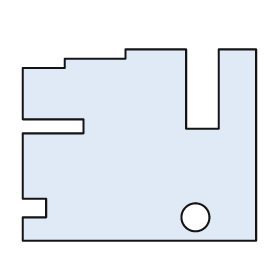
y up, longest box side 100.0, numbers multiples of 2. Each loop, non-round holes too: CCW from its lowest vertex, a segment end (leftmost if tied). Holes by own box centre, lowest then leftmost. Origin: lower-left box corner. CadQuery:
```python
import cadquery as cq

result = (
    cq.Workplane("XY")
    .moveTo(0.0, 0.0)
    .lineTo(100.0, 0.0)
    .lineTo(100.0, 82.0)
    .lineTo(84.0, 82.0)
    .lineTo(84.0, 48.0)
    .lineTo(70.0, 48.0)
    .lineTo(70.0, 82.0)
    .lineTo(44.0, 82.0)
    .lineTo(44.0, 78.0)
    .lineTo(18.0, 78.0)
    .lineTo(18.0, 74.0)
    .lineTo(0.0, 74.0)
    .lineTo(0.0, 52.0)
    .lineTo(26.0, 52.0)
    .lineTo(26.0, 46.0)
    .lineTo(0.0, 46.0)
    .lineTo(0.0, 18.0)
    .lineTo(10.0, 18.0)
    .lineTo(10.0, 10.0)
    .lineTo(0.0, 10.0)
    .close()
    .moveTo(74.0, 10.0)
    .circle(6.0)
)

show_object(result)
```